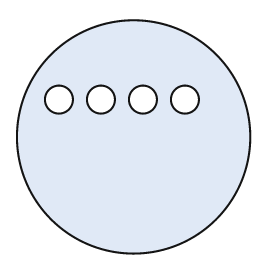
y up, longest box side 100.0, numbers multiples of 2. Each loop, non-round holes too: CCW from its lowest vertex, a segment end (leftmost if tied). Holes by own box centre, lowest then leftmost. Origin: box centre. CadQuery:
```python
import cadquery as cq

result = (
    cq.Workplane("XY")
    .moveTo(0.0, 0.0)
    .circle(50.0)
    .moveTo(-32.0, 16.0)
    .circle(6.0)
    .moveTo(-14.0, 16.0)
    .circle(6.0)
    .moveTo(4.0, 16.0)
    .circle(6.0)
    .moveTo(22.0, 16.0)
    .circle(6.0)
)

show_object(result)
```